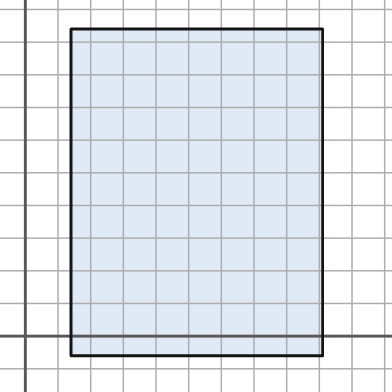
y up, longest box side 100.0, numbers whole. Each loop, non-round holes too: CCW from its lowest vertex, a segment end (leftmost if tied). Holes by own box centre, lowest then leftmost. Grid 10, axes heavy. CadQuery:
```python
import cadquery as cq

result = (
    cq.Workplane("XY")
    .moveTo(14.0, -6.0)
    .lineTo(91.0, -6.0)
    .lineTo(91.0, 94.0)
    .lineTo(14.0, 94.0)
    .close()
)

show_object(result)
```